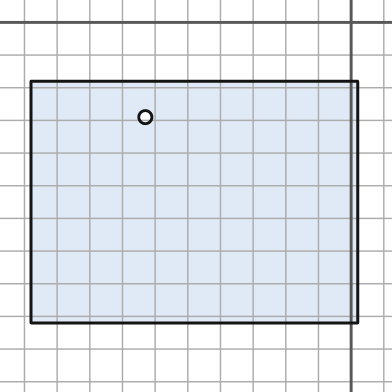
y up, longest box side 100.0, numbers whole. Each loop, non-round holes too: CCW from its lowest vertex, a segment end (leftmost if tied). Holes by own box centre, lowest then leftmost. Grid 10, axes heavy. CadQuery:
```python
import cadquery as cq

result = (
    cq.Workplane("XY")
    .moveTo(-98.0, -92.0)
    .lineTo(2.0, -92.0)
    .lineTo(2.0, -18.0)
    .lineTo(-98.0, -18.0)
    .close()
    .moveTo(-63.0, -29.0)
    .circle(2.0)
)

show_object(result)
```